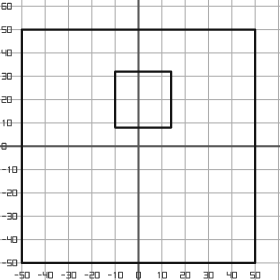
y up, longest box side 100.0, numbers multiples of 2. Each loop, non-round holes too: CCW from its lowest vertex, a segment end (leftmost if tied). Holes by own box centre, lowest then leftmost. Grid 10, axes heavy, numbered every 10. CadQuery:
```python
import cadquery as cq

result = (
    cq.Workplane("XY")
    .moveTo(-50.0, -50.0)
    .lineTo(50.0, -50.0)
    .lineTo(50.0, 50.0)
    .lineTo(-50.0, 50.0)
    .close()
    .moveTo(-10.0, 8.0)
    .lineTo(14.0, 8.0)
    .lineTo(14.0, 32.0)
    .lineTo(-10.0, 32.0)
    .close()
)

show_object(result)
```